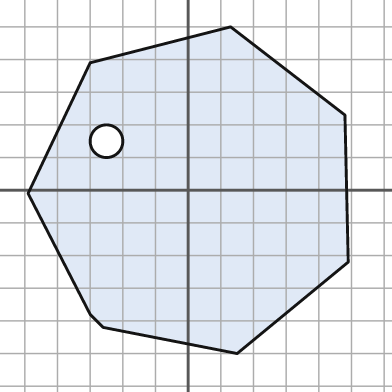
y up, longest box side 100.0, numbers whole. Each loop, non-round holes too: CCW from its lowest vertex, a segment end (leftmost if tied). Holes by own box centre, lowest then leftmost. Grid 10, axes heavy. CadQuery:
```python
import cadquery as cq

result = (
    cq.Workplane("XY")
    .moveTo(15.0, -50.0)
    .lineTo(49.0, -22.0)
    .lineTo(48.0, 23.0)
    .lineTo(13.0, 50.0)
    .lineTo(-30.0, 39.0)
    .lineTo(-49.0, -1.0)
    .lineTo(-30.0, -38.0)
    .lineTo(-26.0, -42.0)
    .close()
    .moveTo(-25.0, 15.0)
    .circle(5.0)
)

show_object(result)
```